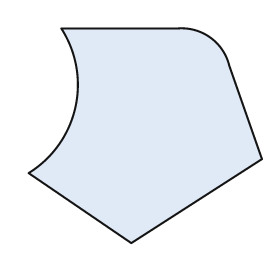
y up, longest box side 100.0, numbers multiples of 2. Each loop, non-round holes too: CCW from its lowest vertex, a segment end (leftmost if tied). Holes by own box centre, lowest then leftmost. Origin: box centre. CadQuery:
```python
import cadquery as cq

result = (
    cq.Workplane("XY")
    .moveTo(-6.0, -46.0)
    .lineTo(50.0, -10.0)
    .lineTo(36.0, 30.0)
    .threePointArc((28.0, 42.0), (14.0, 46.0))
    .lineTo(-36.0, 46.0)
    .threePointArc((-30.0, 12.0), (-50.0, -16.0))
    .close()
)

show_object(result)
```